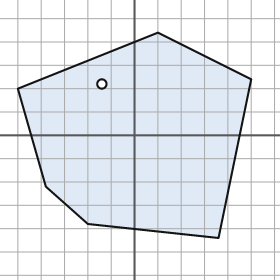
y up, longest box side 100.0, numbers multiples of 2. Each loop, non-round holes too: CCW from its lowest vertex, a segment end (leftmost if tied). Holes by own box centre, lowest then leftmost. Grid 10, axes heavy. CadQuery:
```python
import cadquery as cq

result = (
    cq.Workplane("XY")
    .moveTo(36.0, -44.0)
    .lineTo(50.0, 24.0)
    .lineTo(10.0, 44.0)
    .lineTo(-50.0, 20.0)
    .lineTo(-38.0, -22.0)
    .lineTo(-20.0, -38.0)
    .close()
    .moveTo(-14.0, 22.0)
    .circle(2.0)
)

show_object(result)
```